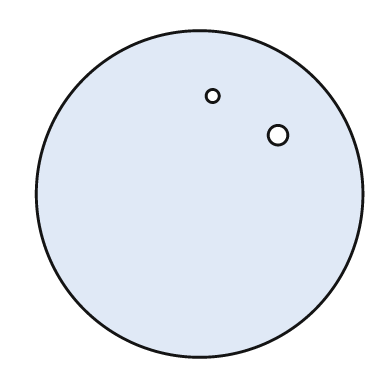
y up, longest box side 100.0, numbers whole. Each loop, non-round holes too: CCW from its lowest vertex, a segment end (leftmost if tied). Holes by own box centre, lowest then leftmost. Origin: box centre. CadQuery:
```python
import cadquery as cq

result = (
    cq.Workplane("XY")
    .moveTo(0.0, 0.0)
    .circle(50.0)
    .moveTo(24.0, 18.0)
    .circle(3.0)
    .moveTo(4.0, 30.0)
    .circle(2.0)
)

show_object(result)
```